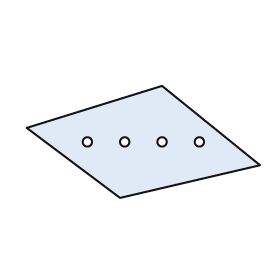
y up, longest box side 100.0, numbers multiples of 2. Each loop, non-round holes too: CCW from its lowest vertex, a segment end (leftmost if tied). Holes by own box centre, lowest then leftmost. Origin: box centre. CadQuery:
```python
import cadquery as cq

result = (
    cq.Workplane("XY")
    .moveTo(-10.0, -24.0)
    .lineTo(50.0, -10.0)
    .lineTo(8.0, 24.0)
    .lineTo(-50.0, 6.0)
    .close()
    .moveTo(-24.0, 0.0)
    .circle(2.0)
    .moveTo(-8.0, 0.0)
    .circle(2.0)
    .moveTo(8.0, 0.0)
    .circle(2.0)
    .moveTo(24.0, 0.0)
    .circle(2.0)
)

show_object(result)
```